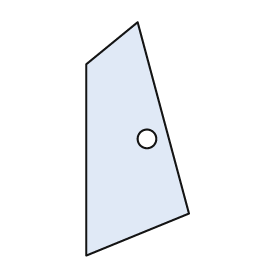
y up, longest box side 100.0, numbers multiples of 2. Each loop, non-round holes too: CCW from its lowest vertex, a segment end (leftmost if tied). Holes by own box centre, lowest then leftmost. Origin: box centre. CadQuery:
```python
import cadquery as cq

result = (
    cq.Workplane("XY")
    .moveTo(-22.0, -50.0)
    .lineTo(22.0, -32.0)
    .lineTo(0.0, 50.0)
    .lineTo(-22.0, 32.0)
    .close()
    .moveTo(4.0, 0.0)
    .circle(4.0)
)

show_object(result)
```